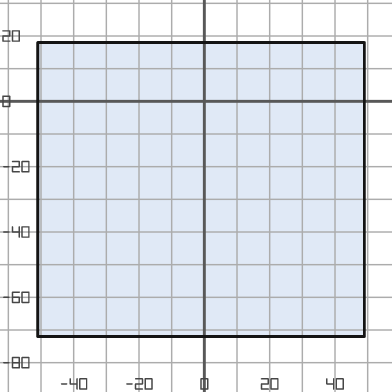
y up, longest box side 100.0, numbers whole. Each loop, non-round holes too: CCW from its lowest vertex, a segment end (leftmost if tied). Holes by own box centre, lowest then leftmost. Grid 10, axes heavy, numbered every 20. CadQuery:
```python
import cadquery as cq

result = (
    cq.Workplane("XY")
    .moveTo(-51.0, -72.0)
    .lineTo(49.0, -72.0)
    .lineTo(49.0, 18.0)
    .lineTo(-51.0, 18.0)
    .close()
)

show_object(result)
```